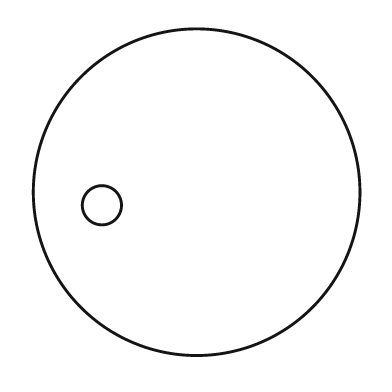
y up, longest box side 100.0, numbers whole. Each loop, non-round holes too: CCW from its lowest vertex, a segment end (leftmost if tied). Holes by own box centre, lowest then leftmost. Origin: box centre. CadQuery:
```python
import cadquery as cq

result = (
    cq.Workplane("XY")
    .moveTo(0.0, 0.0)
    .circle(50.0)
    .moveTo(-29.0, -4.0)
    .circle(6.0)
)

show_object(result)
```